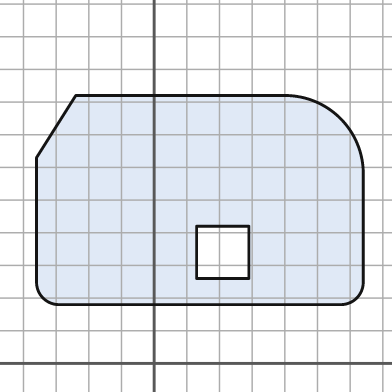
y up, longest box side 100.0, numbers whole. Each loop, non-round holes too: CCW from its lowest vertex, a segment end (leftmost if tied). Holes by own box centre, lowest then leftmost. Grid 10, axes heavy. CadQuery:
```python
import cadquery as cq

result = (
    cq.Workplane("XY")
    .moveTo(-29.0, 18.0)
    .lineTo(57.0, 18.0)
    .threePointArc((62.0, 20.0), (64.0, 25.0))
    .lineTo(64.0, 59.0)
    .threePointArc((57.0, 75.0), (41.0, 82.0))
    .lineTo(-24.0, 82.0)
    .lineTo(-36.0, 63.0)
    .lineTo(-36.0, 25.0)
    .threePointArc((-34.0, 20.0), (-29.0, 18.0))
    .close()
    .moveTo(13.0, 26.0)
    .lineTo(29.0, 26.0)
    .lineTo(29.0, 42.0)
    .lineTo(13.0, 42.0)
    .close()
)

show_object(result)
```